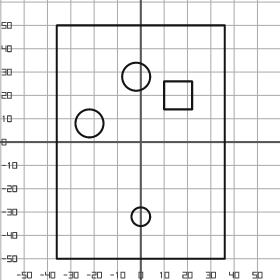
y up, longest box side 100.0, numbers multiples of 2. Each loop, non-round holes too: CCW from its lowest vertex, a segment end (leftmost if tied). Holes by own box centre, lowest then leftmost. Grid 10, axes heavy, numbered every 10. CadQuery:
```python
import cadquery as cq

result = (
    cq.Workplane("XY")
    .moveTo(-36.0, -50.0)
    .lineTo(36.0, -50.0)
    .lineTo(36.0, 50.0)
    .lineTo(-36.0, 50.0)
    .close()
    .moveTo(0.0, -32.0)
    .circle(4.0)
    .moveTo(-22.0, 8.0)
    .circle(6.0)
    .moveTo(10.0, 14.0)
    .lineTo(22.0, 14.0)
    .lineTo(22.0, 26.0)
    .lineTo(10.0, 26.0)
    .close()
    .moveTo(-2.0, 28.0)
    .circle(6.0)
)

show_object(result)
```